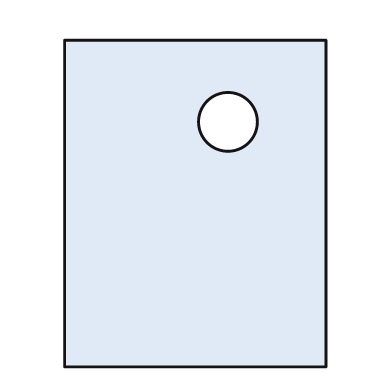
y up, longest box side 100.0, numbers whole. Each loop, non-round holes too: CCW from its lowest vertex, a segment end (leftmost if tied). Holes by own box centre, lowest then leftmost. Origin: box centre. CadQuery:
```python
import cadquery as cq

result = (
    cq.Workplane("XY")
    .moveTo(-40.0, -50.0)
    .lineTo(40.0, -50.0)
    .lineTo(40.0, 50.0)
    .lineTo(-40.0, 50.0)
    .close()
    .moveTo(10.0, 25.0)
    .circle(9.0)
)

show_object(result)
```